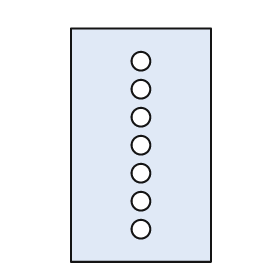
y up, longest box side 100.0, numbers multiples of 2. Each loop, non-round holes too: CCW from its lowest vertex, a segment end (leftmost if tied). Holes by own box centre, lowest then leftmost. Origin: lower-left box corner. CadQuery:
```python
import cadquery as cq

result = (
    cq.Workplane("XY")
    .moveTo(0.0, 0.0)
    .lineTo(60.0, 0.0)
    .lineTo(60.0, 100.0)
    .lineTo(0.0, 100.0)
    .close()
    .moveTo(30.0, 14.0)
    .circle(4.0)
    .moveTo(30.0, 26.0)
    .circle(4.0)
    .moveTo(30.0, 38.0)
    .circle(4.0)
    .moveTo(30.0, 50.0)
    .circle(4.0)
    .moveTo(30.0, 62.0)
    .circle(4.0)
    .moveTo(30.0, 74.0)
    .circle(4.0)
    .moveTo(30.0, 86.0)
    .circle(4.0)
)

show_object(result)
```